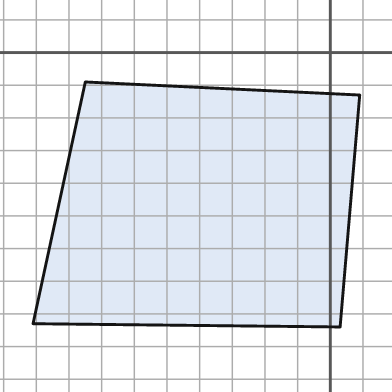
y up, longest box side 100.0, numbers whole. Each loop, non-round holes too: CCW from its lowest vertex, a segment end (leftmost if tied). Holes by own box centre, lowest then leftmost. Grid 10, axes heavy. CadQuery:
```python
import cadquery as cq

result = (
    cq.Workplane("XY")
    .moveTo(3.0, -84.0)
    .lineTo(9.0, -13.0)
    .lineTo(-75.0, -9.0)
    .lineTo(-91.0, -83.0)
    .close()
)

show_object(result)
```